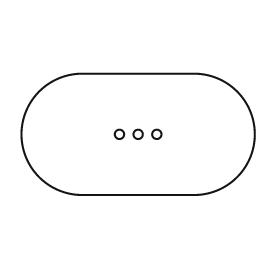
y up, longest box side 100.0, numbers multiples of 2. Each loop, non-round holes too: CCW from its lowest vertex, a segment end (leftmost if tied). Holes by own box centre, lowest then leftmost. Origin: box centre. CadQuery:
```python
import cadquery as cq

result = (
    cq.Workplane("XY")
    .moveTo(-24.0, -26.0)
    .lineTo(24.0, -26.0)
    .threePointArc((50.0, 0.0), (24.0, 26.0))
    .lineTo(-24.0, 26.0)
    .threePointArc((-50.0, 0.0), (-24.0, -26.0))
    .close()
    .moveTo(-8.0, 0.0)
    .circle(2.0)
    .moveTo(0.0, 0.0)
    .circle(2.0)
    .moveTo(8.0, 0.0)
    .circle(2.0)
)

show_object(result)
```